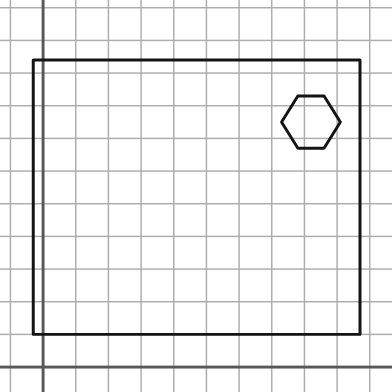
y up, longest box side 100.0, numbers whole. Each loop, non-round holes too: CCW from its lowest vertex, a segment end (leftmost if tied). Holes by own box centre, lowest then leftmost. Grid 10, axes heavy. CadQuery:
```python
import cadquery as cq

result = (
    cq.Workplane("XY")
    .moveTo(-3.0, 10.0)
    .lineTo(97.0, 10.0)
    .lineTo(97.0, 94.0)
    .lineTo(-3.0, 94.0)
    .close()
    .moveTo(78.0, 67.0)
    .lineTo(86.0, 67.0)
    .lineTo(91.0, 75.0)
    .lineTo(86.0, 83.0)
    .lineTo(78.0, 83.0)
    .lineTo(73.0, 75.0)
    .close()
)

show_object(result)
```